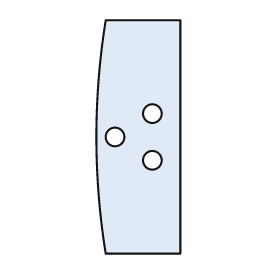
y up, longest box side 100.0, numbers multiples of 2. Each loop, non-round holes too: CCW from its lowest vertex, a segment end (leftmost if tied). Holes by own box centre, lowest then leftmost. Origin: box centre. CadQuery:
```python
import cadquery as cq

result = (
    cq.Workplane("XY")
    .moveTo(-14.0, -50.0)
    .lineTo(18.0, -50.0)
    .lineTo(18.0, 50.0)
    .lineTo(-14.0, 50.0)
    .threePointArc((-18.0, 0.0), (-14.0, -50.0))
    .close()
    .moveTo(6.0, -10.0)
    .circle(4.0)
    .moveTo(-10.0, 0.0)
    .circle(4.0)
    .moveTo(6.0, 10.0)
    .circle(4.0)
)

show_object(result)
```